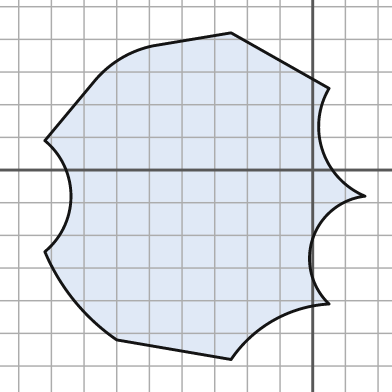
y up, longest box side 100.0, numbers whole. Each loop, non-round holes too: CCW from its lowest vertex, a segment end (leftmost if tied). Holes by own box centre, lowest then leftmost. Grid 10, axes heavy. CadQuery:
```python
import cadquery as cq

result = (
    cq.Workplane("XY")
    .moveTo(-25.0, -58.0)
    .threePointArc((-12.0, -46.0), (5.0, -41.0))
    .threePointArc((0.0, -21.0), (16.0, -8.0))
    .threePointArc((3.0, 6.0), (5.0, 25.0))
    .lineTo(-25.0, 42.0)
    .lineTo(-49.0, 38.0)
    .threePointArc((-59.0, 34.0), (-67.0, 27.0))
    .lineTo(-82.0, 9.0)
    .threePointArc((-74.0, -8.0), (-82.0, -25.0))
    .threePointArc((-73.0, -40.0), (-60.0, -52.0))
    .close()
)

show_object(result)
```